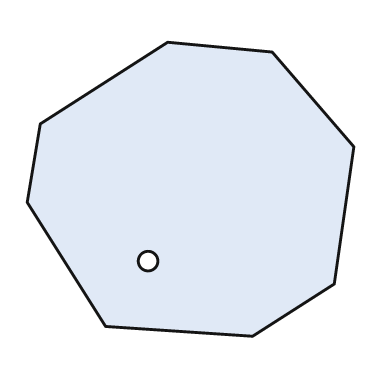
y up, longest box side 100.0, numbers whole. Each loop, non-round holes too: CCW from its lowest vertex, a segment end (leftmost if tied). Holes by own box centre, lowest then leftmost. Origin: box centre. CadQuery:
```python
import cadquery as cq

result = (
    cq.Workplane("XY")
    .moveTo(19.0, -45.0)
    .lineTo(44.0, -29.0)
    .lineTo(50.0, 13.0)
    .lineTo(25.0, 42.0)
    .lineTo(-7.0, 45.0)
    .lineTo(-46.0, 20.0)
    .lineTo(-50.0, -4.0)
    .lineTo(-26.0, -42.0)
    .close()
    .moveTo(-13.0, -22.0)
    .circle(3.0)
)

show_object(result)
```